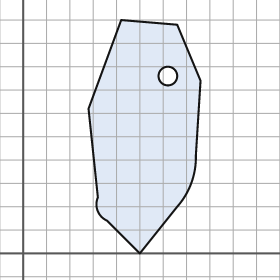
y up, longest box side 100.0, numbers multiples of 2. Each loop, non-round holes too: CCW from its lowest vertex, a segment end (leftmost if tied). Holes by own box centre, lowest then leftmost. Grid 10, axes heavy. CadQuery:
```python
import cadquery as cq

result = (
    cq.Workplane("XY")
    .moveTo(50.0, 0.0)
    .lineTo(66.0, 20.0)
    .threePointArc((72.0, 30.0), (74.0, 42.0))
    .lineTo(76.0, 74.0)
    .lineTo(66.0, 98.0)
    .lineTo(42.0, 100.0)
    .lineTo(28.0, 62.0)
    .lineTo(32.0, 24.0)
    .threePointArc((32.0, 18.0), (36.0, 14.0))
    .close()
    .moveTo(62.0, 76.0)
    .circle(4.0)
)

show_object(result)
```